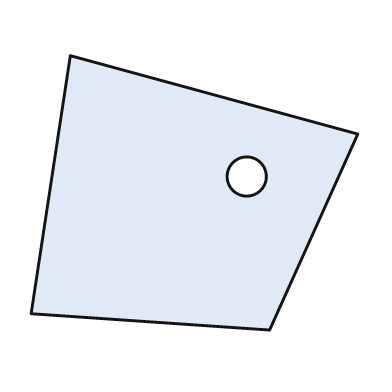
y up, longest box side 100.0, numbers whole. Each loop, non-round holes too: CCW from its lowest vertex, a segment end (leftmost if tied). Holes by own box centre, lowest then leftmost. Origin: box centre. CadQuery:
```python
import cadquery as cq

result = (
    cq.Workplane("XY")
    .moveTo(23.0, -42.0)
    .lineTo(50.0, 18.0)
    .lineTo(-38.0, 42.0)
    .lineTo(-50.0, -37.0)
    .close()
    .moveTo(16.0, 5.0)
    .circle(6.0)
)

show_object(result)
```